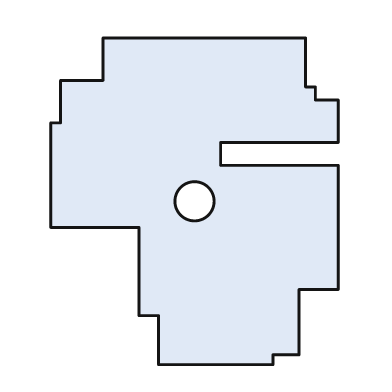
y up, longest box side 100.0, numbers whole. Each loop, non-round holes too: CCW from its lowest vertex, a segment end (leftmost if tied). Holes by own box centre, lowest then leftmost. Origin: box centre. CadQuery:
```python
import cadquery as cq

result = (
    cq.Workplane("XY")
    .moveTo(-11.0, -50.0)
    .lineTo(24.0, -50.0)
    .lineTo(24.0, -47.0)
    .lineTo(32.0, -47.0)
    .lineTo(32.0, -27.0)
    .lineTo(44.0, -27.0)
    .lineTo(44.0, 11.0)
    .lineTo(8.0, 11.0)
    .lineTo(8.0, 18.0)
    .lineTo(44.0, 18.0)
    .lineTo(44.0, 31.0)
    .lineTo(37.0, 31.0)
    .lineTo(37.0, 35.0)
    .lineTo(34.0, 35.0)
    .lineTo(34.0, 50.0)
    .lineTo(-28.0, 50.0)
    .lineTo(-28.0, 37.0)
    .lineTo(-41.0, 37.0)
    .lineTo(-41.0, 24.0)
    .lineTo(-44.0, 24.0)
    .lineTo(-44.0, -8.0)
    .lineTo(-17.0, -8.0)
    .lineTo(-17.0, -35.0)
    .lineTo(-11.0, -35.0)
    .close()
    .moveTo(0.0, 0.0)
    .circle(6.0)
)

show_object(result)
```